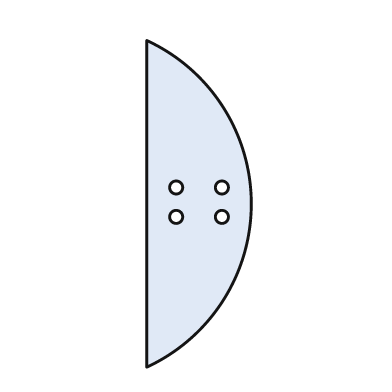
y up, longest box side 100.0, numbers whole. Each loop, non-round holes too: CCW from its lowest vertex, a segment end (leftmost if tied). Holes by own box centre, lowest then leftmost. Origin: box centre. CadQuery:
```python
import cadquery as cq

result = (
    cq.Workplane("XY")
    .moveTo(-16.0, -50.0)
    .threePointArc((16.0, 0.0), (-16.0, 50.0))
    .close()
    .moveTo(-7.0, -4.0)
    .circle(2.0)
    .moveTo(7.0, -4.0)
    .circle(2.0)
    .moveTo(-7.0, 5.0)
    .circle(2.0)
    .moveTo(7.0, 5.0)
    .circle(2.0)
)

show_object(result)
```